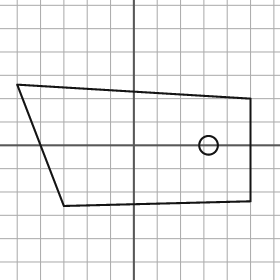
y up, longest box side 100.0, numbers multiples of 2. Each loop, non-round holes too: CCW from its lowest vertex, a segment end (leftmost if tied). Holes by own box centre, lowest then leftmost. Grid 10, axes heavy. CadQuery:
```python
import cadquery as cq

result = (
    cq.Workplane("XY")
    .moveTo(-30.0, -26.0)
    .lineTo(50.0, -24.0)
    .lineTo(50.0, 20.0)
    .lineTo(-50.0, 26.0)
    .close()
    .moveTo(32.0, 0.0)
    .circle(4.0)
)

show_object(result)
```